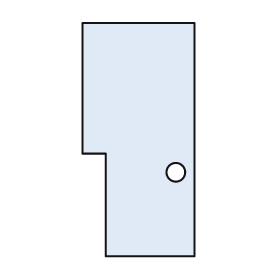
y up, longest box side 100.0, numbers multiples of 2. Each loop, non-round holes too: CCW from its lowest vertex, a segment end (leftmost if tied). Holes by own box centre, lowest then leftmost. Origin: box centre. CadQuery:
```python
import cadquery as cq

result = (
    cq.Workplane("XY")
    .moveTo(-14.0, -50.0)
    .lineTo(24.0, -50.0)
    .lineTo(24.0, 50.0)
    .lineTo(-24.0, 50.0)
    .lineTo(-24.0, -6.0)
    .lineTo(-14.0, -6.0)
    .close()
    .moveTo(16.0, -14.0)
    .circle(4.0)
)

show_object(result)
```